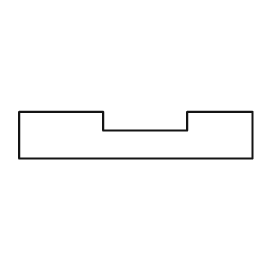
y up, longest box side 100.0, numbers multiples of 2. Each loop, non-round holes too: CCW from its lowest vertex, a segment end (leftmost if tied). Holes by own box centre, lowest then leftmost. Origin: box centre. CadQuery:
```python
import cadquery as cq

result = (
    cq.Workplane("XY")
    .moveTo(-50.0, -10.0)
    .lineTo(50.0, -10.0)
    .lineTo(50.0, 10.0)
    .lineTo(22.0, 10.0)
    .lineTo(22.0, 2.0)
    .lineTo(-14.0, 2.0)
    .lineTo(-14.0, 10.0)
    .lineTo(-50.0, 10.0)
    .close()
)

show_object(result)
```